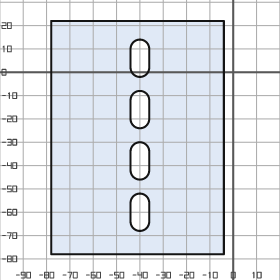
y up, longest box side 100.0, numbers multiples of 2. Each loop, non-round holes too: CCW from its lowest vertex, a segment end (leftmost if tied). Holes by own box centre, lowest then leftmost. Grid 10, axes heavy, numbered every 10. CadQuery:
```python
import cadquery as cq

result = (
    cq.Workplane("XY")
    .moveTo(-78.0, -78.0)
    .lineTo(-4.0, -78.0)
    .lineTo(-4.0, 22.0)
    .lineTo(-78.0, 22.0)
    .close()
    .moveTo(-44.0, -64.0)
    .threePointArc((-40.0, -68.0), (-36.0, -64.0))
    .lineTo(-36.0, -56.0)
    .threePointArc((-40.0, -52.0), (-44.0, -56.0))
    .close()
    .moveTo(-44.0, -42.0)
    .threePointArc((-40.0, -46.0), (-36.0, -42.0))
    .lineTo(-36.0, -34.0)
    .threePointArc((-40.0, -30.0), (-44.0, -34.0))
    .close()
    .moveTo(-44.0, -20.0)
    .threePointArc((-40.0, -24.0), (-36.0, -20.0))
    .lineTo(-36.0, -12.0)
    .threePointArc((-40.0, -8.0), (-44.0, -12.0))
    .close()
    .moveTo(-44.0, 2.0)
    .threePointArc((-40.0, -2.0), (-36.0, 2.0))
    .lineTo(-36.0, 10.0)
    .threePointArc((-40.0, 14.0), (-44.0, 10.0))
    .close()
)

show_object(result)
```